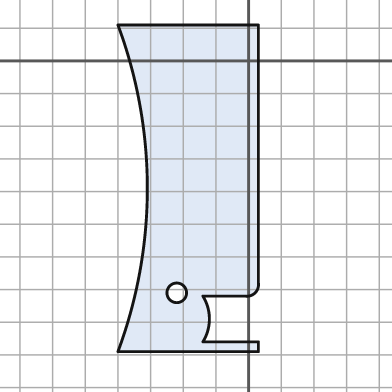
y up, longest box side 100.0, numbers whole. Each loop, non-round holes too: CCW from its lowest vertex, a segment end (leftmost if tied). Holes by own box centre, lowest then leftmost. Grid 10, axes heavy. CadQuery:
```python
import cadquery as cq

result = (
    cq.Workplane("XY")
    .moveTo(-40.0, -89.0)
    .lineTo(3.0, -89.0)
    .lineTo(3.0, -86.0)
    .lineTo(-14.0, -86.0)
    .threePointArc((-12.0, -79.0), (-14.0, -72.0))
    .lineTo(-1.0, -72.0)
    .threePointArc((2.0, -71.0), (3.0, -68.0))
    .lineTo(3.0, 11.0)
    .lineTo(-40.0, 11.0)
    .threePointArc((-31.0, -39.0), (-40.0, -89.0))
    .close()
    .moveTo(-22.0, -71.0)
    .circle(3.0)
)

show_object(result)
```